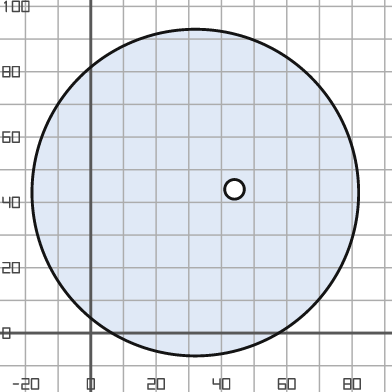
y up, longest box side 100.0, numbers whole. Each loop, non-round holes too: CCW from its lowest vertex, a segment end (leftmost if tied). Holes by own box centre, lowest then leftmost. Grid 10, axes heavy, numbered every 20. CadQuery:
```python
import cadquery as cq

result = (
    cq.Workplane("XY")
    .moveTo(32.0, 43.0)
    .circle(50.0)
    .moveTo(44.0, 44.0)
    .circle(3.0)
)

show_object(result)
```